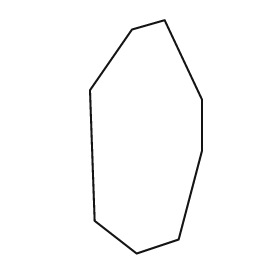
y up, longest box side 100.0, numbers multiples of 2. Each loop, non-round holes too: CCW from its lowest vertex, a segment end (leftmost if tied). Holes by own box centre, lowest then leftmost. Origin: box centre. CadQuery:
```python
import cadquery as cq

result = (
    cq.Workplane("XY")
    .moveTo(-4.0, -50.0)
    .lineTo(14.0, -44.0)
    .lineTo(24.0, -6.0)
    .lineTo(24.0, 16.0)
    .lineTo(8.0, 50.0)
    .lineTo(-6.0, 46.0)
    .lineTo(-24.0, 20.0)
    .lineTo(-22.0, -36.0)
    .close()
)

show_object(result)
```